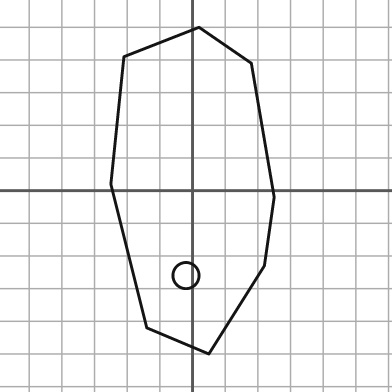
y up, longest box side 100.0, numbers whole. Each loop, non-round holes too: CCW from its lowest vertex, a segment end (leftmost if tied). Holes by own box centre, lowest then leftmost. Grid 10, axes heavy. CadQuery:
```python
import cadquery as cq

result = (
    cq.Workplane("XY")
    .moveTo(5.0, -50.0)
    .lineTo(22.0, -23.0)
    .lineTo(25.0, -2.0)
    .lineTo(18.0, 39.0)
    .lineTo(2.0, 50.0)
    .lineTo(-21.0, 41.0)
    .lineTo(-25.0, 2.0)
    .lineTo(-14.0, -42.0)
    .close()
    .moveTo(-2.0, -26.0)
    .circle(4.0)
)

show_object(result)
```